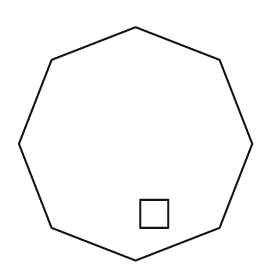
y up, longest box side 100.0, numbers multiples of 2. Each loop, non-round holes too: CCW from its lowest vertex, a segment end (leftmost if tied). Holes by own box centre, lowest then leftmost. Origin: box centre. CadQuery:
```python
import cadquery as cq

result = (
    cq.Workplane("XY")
    .moveTo(0.0, -50.0)
    .lineTo(36.0, -36.0)
    .lineTo(50.0, 0.0)
    .lineTo(36.0, 36.0)
    .lineTo(0.0, 50.0)
    .lineTo(-36.0, 36.0)
    .lineTo(-50.0, 0.0)
    .lineTo(-36.0, -36.0)
    .close()
    .moveTo(2.0, -36.0)
    .lineTo(14.0, -36.0)
    .lineTo(14.0, -24.0)
    .lineTo(2.0, -24.0)
    .close()
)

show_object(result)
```